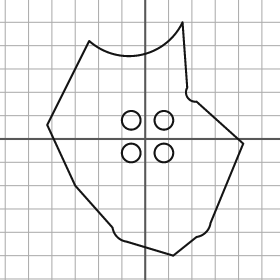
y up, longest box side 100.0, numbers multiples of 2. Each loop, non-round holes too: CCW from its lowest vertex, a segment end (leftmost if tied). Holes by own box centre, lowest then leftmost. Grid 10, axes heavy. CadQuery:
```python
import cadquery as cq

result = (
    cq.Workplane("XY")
    .moveTo(12.0, -50.0)
    .lineTo(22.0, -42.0)
    .threePointArc((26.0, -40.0), (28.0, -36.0))
    .lineTo(42.0, -2.0)
    .lineTo(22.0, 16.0)
    .threePointArc((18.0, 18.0), (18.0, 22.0))
    .lineTo(16.0, 50.0)
    .threePointArc((-2.0, 36.0), (-24.0, 42.0))
    .lineTo(-42.0, 6.0)
    .lineTo(-30.0, -20.0)
    .lineTo(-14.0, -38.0)
    .threePointArc((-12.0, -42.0), (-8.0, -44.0))
    .close()
    .moveTo(-6.0, -6.0)
    .circle(4.0)
    .moveTo(8.0, -6.0)
    .circle(4.0)
    .moveTo(-6.0, 8.0)
    .circle(4.0)
    .moveTo(8.0, 8.0)
    .circle(4.0)
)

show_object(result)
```